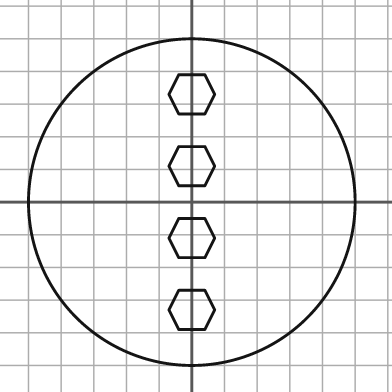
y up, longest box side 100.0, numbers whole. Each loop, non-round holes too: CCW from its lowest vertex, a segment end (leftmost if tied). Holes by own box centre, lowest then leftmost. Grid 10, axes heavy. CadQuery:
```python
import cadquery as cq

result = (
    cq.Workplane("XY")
    .moveTo(0.0, 0.0)
    .circle(50.0)
    .moveTo(-4.0, -39.0)
    .lineTo(4.0, -39.0)
    .lineTo(7.0, -33.0)
    .lineTo(4.0, -27.0)
    .lineTo(-4.0, -27.0)
    .lineTo(-7.0, -33.0)
    .close()
    .moveTo(-4.0, -17.0)
    .lineTo(4.0, -17.0)
    .lineTo(7.0, -11.0)
    .lineTo(4.0, -5.0)
    .lineTo(-4.0, -5.0)
    .lineTo(-7.0, -11.0)
    .close()
    .moveTo(-4.0, 5.0)
    .lineTo(4.0, 5.0)
    .lineTo(7.0, 11.0)
    .lineTo(4.0, 17.0)
    .lineTo(-4.0, 17.0)
    .lineTo(-7.0, 11.0)
    .close()
    .moveTo(-4.0, 27.0)
    .lineTo(4.0, 27.0)
    .lineTo(7.0, 33.0)
    .lineTo(4.0, 39.0)
    .lineTo(-4.0, 39.0)
    .lineTo(-7.0, 33.0)
    .close()
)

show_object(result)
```